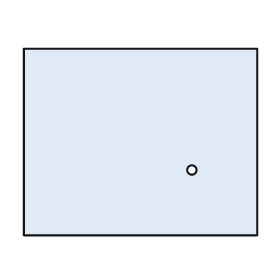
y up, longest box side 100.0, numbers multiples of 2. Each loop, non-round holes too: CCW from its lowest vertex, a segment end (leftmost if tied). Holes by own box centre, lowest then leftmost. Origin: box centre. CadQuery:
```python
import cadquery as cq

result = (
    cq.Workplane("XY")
    .moveTo(-50.0, -40.0)
    .lineTo(50.0, -40.0)
    .lineTo(50.0, 40.0)
    .lineTo(-50.0, 40.0)
    .close()
    .moveTo(22.0, -12.0)
    .circle(2.0)
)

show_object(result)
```